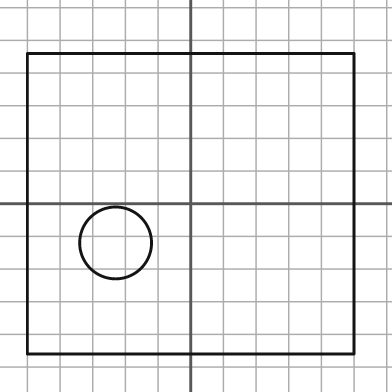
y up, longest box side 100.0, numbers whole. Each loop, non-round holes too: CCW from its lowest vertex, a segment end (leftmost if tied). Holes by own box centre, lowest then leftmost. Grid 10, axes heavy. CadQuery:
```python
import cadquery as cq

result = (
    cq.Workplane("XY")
    .moveTo(-50.0, -46.0)
    .lineTo(50.0, -46.0)
    .lineTo(50.0, 46.0)
    .lineTo(-50.0, 46.0)
    .close()
    .moveTo(-23.0, -12.0)
    .circle(11.0)
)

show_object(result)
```